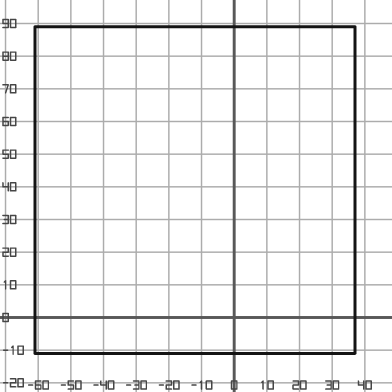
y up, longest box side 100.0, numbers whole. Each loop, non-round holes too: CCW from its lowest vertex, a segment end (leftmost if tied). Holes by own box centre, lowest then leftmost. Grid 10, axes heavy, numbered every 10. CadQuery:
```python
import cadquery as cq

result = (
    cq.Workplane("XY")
    .moveTo(-61.0, -11.0)
    .lineTo(37.0, -11.0)
    .lineTo(37.0, 89.0)
    .lineTo(-61.0, 89.0)
    .close()
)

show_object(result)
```